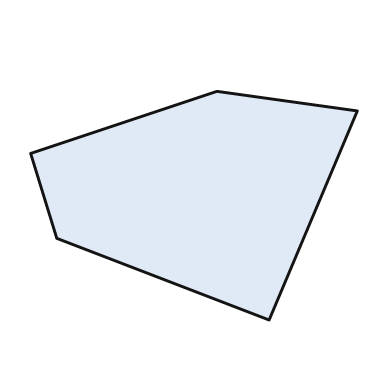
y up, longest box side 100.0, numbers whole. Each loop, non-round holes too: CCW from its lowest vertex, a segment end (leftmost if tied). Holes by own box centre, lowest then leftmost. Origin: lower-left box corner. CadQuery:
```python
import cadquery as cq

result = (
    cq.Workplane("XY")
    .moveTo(73.0, 0.0)
    .lineTo(100.0, 64.0)
    .lineTo(57.0, 70.0)
    .lineTo(0.0, 51.0)
    .lineTo(8.0, 25.0)
    .close()
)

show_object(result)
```